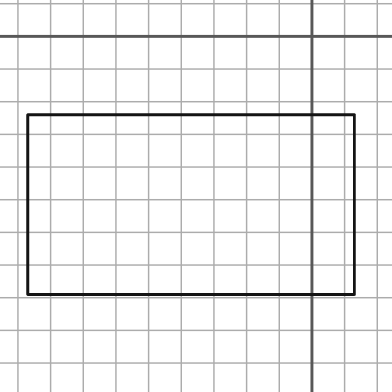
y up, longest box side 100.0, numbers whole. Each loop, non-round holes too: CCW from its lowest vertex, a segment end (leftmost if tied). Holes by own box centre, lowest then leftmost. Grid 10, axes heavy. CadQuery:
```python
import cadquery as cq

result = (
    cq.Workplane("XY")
    .moveTo(-87.0, -79.0)
    .lineTo(13.0, -79.0)
    .lineTo(13.0, -24.0)
    .lineTo(-87.0, -24.0)
    .close()
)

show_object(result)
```